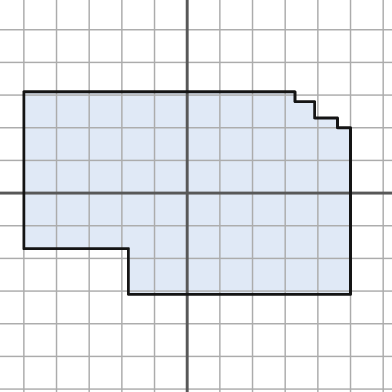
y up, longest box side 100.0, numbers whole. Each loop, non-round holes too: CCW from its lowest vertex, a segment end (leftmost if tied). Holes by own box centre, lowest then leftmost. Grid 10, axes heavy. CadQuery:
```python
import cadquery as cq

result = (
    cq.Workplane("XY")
    .moveTo(-18.0, -31.0)
    .lineTo(50.0, -31.0)
    .lineTo(50.0, 20.0)
    .lineTo(46.0, 20.0)
    .lineTo(46.0, 23.0)
    .lineTo(39.0, 23.0)
    .lineTo(39.0, 28.0)
    .lineTo(33.0, 28.0)
    .lineTo(33.0, 31.0)
    .lineTo(-50.0, 31.0)
    .lineTo(-50.0, -17.0)
    .lineTo(-18.0, -17.0)
    .close()
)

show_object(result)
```